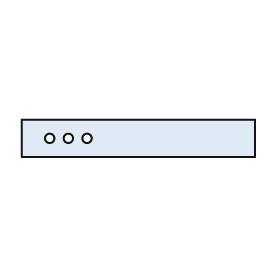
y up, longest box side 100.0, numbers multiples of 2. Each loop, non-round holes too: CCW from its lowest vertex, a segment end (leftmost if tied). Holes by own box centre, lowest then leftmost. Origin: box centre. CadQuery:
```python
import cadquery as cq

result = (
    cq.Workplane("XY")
    .moveTo(-50.0, -8.0)
    .lineTo(50.0, -8.0)
    .lineTo(50.0, 8.0)
    .lineTo(-50.0, 8.0)
    .close()
    .moveTo(-38.0, 0.0)
    .circle(2.0)
    .moveTo(-30.0, 0.0)
    .circle(2.0)
    .moveTo(-22.0, 0.0)
    .circle(2.0)
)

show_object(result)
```